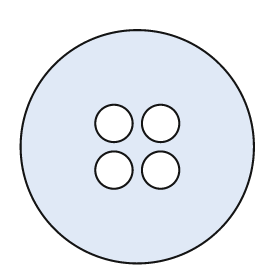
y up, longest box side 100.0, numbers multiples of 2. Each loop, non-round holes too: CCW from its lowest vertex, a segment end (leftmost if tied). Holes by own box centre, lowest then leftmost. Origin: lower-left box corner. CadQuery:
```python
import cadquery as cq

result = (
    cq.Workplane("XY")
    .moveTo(50.0, 50.0)
    .circle(50.0)
    .moveTo(40.0, 40.0)
    .circle(8.0)
    .moveTo(60.0, 40.0)
    .circle(8.0)
    .moveTo(40.0, 60.0)
    .circle(8.0)
    .moveTo(60.0, 60.0)
    .circle(8.0)
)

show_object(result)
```